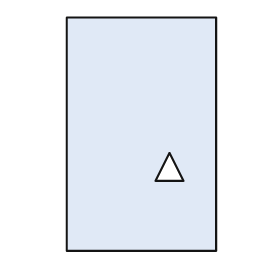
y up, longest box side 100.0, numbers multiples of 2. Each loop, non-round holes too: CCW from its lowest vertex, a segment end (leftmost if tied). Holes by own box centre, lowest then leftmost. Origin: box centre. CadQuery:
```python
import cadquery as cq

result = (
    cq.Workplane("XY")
    .moveTo(-32.0, -50.0)
    .lineTo(32.0, -50.0)
    .lineTo(32.0, 50.0)
    .lineTo(-32.0, 50.0)
    .close()
    .moveTo(6.0, -20.0)
    .lineTo(18.0, -20.0)
    .lineTo(12.0, -8.0)
    .close()
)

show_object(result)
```